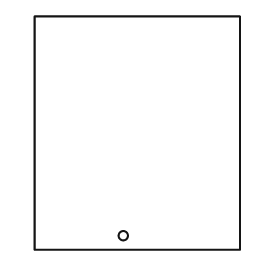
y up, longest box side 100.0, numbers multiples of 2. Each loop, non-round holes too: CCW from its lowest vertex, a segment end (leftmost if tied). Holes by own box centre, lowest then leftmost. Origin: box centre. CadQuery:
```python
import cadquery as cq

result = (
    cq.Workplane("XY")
    .moveTo(-44.0, -50.0)
    .lineTo(44.0, -50.0)
    .lineTo(44.0, 50.0)
    .lineTo(-44.0, 50.0)
    .close()
    .moveTo(-6.0, -44.0)
    .circle(2.0)
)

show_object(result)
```